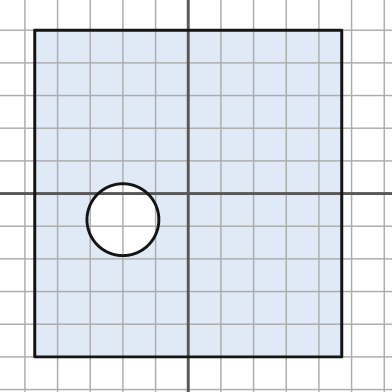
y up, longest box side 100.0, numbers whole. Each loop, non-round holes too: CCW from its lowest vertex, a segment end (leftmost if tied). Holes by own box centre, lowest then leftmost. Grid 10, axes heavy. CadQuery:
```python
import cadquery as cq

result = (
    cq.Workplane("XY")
    .moveTo(-47.0, -50.0)
    .lineTo(47.0, -50.0)
    .lineTo(47.0, 50.0)
    .lineTo(-47.0, 50.0)
    .close()
    .moveTo(-20.0, -8.0)
    .circle(11.0)
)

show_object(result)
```